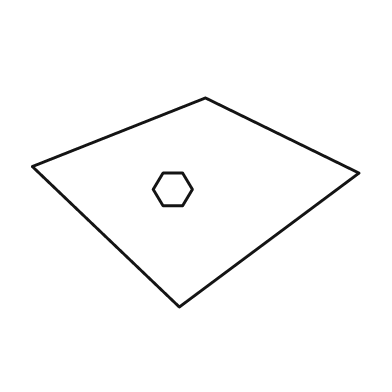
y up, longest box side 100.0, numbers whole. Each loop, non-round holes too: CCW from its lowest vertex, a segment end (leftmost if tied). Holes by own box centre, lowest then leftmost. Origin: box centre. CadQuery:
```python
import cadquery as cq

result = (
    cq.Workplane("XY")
    .moveTo(-5.0, -32.0)
    .lineTo(50.0, 9.0)
    .lineTo(3.0, 32.0)
    .lineTo(-50.0, 11.0)
    .close()
    .moveTo(-10.0, -1.0)
    .lineTo(-4.0, -1.0)
    .lineTo(-1.0, 4.0)
    .lineTo(-4.0, 9.0)
    .lineTo(-10.0, 9.0)
    .lineTo(-13.0, 4.0)
    .close()
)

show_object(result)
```